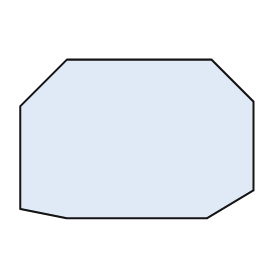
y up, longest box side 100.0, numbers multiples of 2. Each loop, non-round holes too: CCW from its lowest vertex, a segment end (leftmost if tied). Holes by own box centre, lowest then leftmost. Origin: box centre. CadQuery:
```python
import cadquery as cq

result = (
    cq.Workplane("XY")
    .moveTo(-30.0, -34.0)
    .lineTo(30.0, -34.0)
    .lineTo(50.0, -22.0)
    .lineTo(50.0, 16.0)
    .lineTo(32.0, 34.0)
    .lineTo(-30.0, 34.0)
    .lineTo(-50.0, 14.0)
    .lineTo(-50.0, -30.0)
    .close()
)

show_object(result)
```